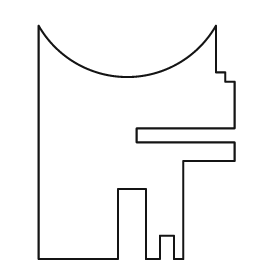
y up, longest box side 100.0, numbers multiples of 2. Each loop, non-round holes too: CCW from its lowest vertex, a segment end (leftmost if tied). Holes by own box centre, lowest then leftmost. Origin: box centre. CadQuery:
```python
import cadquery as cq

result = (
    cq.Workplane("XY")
    .moveTo(-42.0, -50.0)
    .lineTo(-8.0, -50.0)
    .lineTo(-8.0, -20.0)
    .lineTo(4.0, -20.0)
    .lineTo(4.0, -50.0)
    .lineTo(10.0, -50.0)
    .lineTo(10.0, -40.0)
    .lineTo(16.0, -40.0)
    .lineTo(16.0, -50.0)
    .lineTo(20.0, -50.0)
    .lineTo(20.0, -8.0)
    .lineTo(42.0, -8.0)
    .lineTo(42.0, 0.0)
    .lineTo(0.0, 0.0)
    .lineTo(0.0, 6.0)
    .lineTo(42.0, 6.0)
    .lineTo(42.0, 26.0)
    .lineTo(38.0, 26.0)
    .lineTo(38.0, 30.0)
    .lineTo(34.0, 30.0)
    .lineTo(34.0, 50.0)
    .threePointArc((-4.0, 28.0), (-42.0, 50.0))
    .close()
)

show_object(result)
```